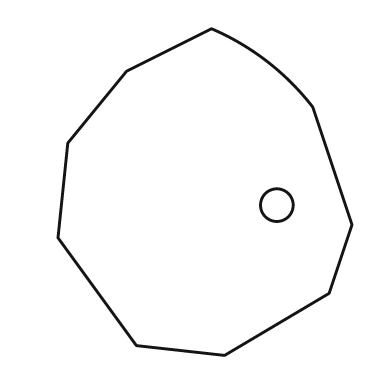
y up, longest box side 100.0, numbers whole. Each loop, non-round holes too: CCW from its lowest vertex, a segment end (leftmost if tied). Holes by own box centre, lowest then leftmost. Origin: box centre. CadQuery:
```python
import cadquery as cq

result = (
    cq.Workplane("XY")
    .moveTo(6.0, -50.0)
    .lineTo(38.0, -31.0)
    .lineTo(45.0, -10.0)
    .lineTo(33.0, 26.0)
    .threePointArc((19.0, 40.0), (2.0, 50.0))
    .lineTo(-24.0, 37.0)
    .lineTo(-42.0, 15.0)
    .lineTo(-45.0, -14.0)
    .lineTo(-21.0, -47.0)
    .close()
    .moveTo(22.0, -4.0)
    .circle(5.0)
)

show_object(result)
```